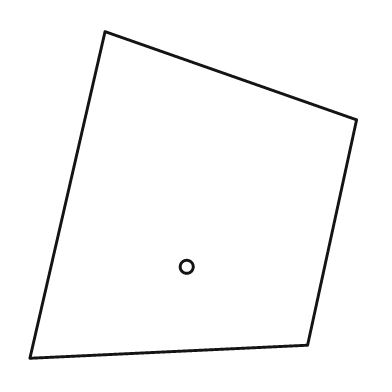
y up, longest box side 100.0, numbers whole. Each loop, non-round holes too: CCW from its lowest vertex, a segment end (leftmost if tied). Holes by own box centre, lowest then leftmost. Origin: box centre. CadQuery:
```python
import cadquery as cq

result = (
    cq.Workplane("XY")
    .moveTo(-50.0, -50.0)
    .lineTo(35.0, -46.0)
    .lineTo(50.0, 23.0)
    .lineTo(-27.0, 50.0)
    .close()
    .moveTo(-2.0, -22.0)
    .circle(2.0)
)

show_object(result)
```